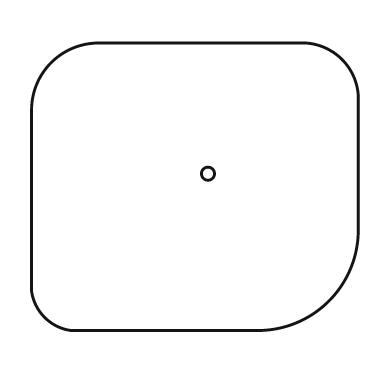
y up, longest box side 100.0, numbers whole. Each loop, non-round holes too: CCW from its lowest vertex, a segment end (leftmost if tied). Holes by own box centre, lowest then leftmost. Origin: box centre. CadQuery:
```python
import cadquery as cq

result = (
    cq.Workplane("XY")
    .moveTo(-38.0, -44.0)
    .lineTo(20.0, -44.0)
    .threePointArc((41.0, -35.0), (50.0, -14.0))
    .lineTo(50.0, 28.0)
    .threePointArc((45.0, 39.0), (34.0, 44.0))
    .lineTo(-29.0, 44.0)
    .threePointArc((-44.0, 38.0), (-50.0, 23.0))
    .lineTo(-50.0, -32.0)
    .threePointArc((-46.0, -40.0), (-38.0, -44.0))
    .close()
    .moveTo(4.0, 4.0)
    .circle(2.0)
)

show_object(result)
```